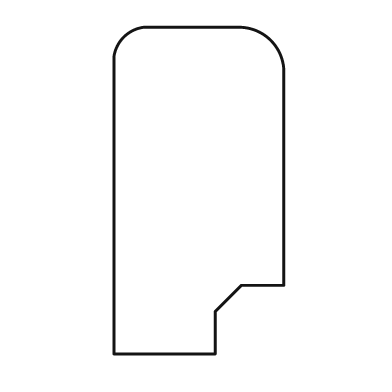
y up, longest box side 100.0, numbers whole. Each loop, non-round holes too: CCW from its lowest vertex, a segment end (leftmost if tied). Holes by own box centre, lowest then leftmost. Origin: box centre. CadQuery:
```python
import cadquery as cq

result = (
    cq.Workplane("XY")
    .moveTo(-26.0, -50.0)
    .lineTo(5.0, -50.0)
    .lineTo(5.0, -37.0)
    .lineTo(13.0, -29.0)
    .lineTo(26.0, -29.0)
    .lineTo(26.0, 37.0)
    .threePointArc((22.0, 46.0), (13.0, 50.0))
    .lineTo(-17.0, 50.0)
    .threePointArc((-23.0, 47.0), (-26.0, 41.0))
    .close()
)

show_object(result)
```